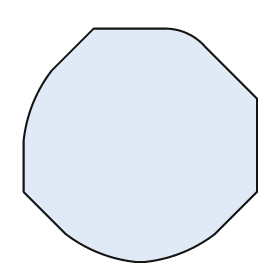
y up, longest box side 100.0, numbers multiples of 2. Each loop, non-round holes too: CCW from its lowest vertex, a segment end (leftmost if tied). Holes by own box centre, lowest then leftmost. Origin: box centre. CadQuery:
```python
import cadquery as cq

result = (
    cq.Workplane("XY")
    .moveTo(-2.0, -50.0)
    .lineTo(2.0, -50.0)
    .threePointArc((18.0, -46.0), (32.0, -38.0))
    .lineTo(50.0, -20.0)
    .lineTo(50.0, 20.0)
    .lineTo(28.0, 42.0)
    .threePointArc((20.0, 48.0), (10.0, 50.0))
    .lineTo(-20.0, 50.0)
    .lineTo(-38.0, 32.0)
    .threePointArc((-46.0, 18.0), (-50.0, 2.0))
    .lineTo(-50.0, -20.0)
    .lineTo(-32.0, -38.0)
    .threePointArc((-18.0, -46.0), (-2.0, -50.0))
    .close()
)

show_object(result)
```